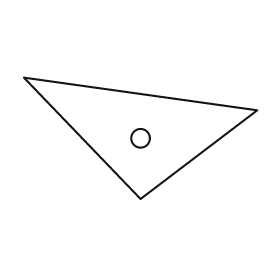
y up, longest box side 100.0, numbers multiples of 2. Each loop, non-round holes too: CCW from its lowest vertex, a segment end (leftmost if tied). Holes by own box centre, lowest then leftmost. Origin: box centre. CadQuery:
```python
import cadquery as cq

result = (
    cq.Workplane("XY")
    .moveTo(0.0, -26.0)
    .lineTo(50.0, 12.0)
    .lineTo(-50.0, 26.0)
    .close()
    .moveTo(0.0, 0.0)
    .circle(4.0)
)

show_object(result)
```